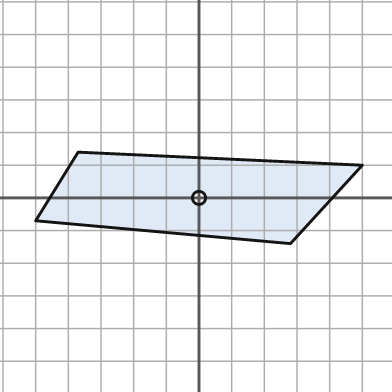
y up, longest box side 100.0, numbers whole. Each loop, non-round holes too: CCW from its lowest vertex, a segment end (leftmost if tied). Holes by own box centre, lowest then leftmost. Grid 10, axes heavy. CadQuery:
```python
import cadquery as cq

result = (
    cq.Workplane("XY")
    .moveTo(28.0, -14.0)
    .lineTo(50.0, 10.0)
    .lineTo(-37.0, 14.0)
    .lineTo(-50.0, -7.0)
    .close()
    .moveTo(0.0, 0.0)
    .circle(2.0)
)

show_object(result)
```